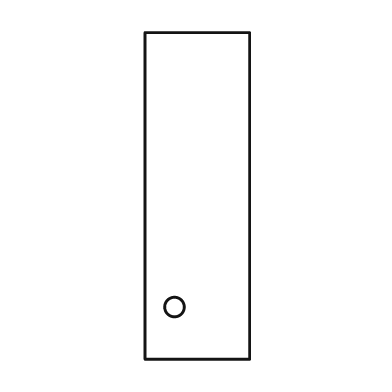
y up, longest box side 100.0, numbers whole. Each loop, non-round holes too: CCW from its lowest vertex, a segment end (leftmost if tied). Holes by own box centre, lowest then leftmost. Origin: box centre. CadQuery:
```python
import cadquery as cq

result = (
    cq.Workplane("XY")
    .moveTo(-16.0, -50.0)
    .lineTo(16.0, -50.0)
    .lineTo(16.0, 50.0)
    .lineTo(-16.0, 50.0)
    .close()
    .moveTo(-7.0, -34.0)
    .circle(3.0)
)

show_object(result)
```